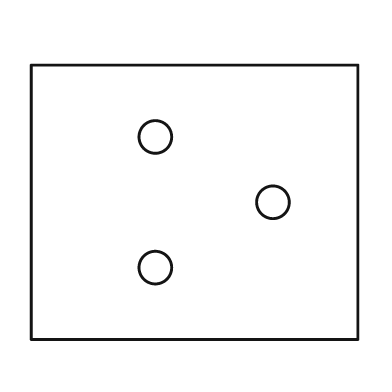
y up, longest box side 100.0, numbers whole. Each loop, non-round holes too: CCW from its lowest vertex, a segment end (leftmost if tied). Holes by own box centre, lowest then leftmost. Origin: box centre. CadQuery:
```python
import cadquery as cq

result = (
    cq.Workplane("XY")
    .moveTo(-50.0, -42.0)
    .lineTo(50.0, -42.0)
    .lineTo(50.0, 42.0)
    .lineTo(-50.0, 42.0)
    .close()
    .moveTo(-12.0, -20.0)
    .circle(5.0)
    .moveTo(24.0, 0.0)
    .circle(5.0)
    .moveTo(-12.0, 20.0)
    .circle(5.0)
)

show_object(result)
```